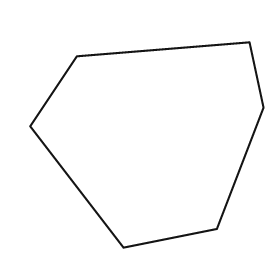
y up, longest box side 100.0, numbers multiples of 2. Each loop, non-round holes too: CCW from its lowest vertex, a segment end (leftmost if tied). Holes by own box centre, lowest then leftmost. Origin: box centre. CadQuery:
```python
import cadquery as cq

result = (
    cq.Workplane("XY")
    .moveTo(-10.0, -44.0)
    .lineTo(30.0, -36.0)
    .lineTo(50.0, 16.0)
    .lineTo(44.0, 44.0)
    .lineTo(-30.0, 38.0)
    .lineTo(-50.0, 8.0)
    .close()
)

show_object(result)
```